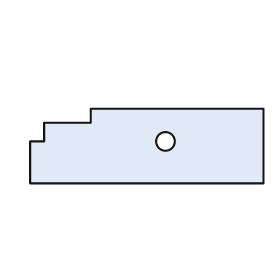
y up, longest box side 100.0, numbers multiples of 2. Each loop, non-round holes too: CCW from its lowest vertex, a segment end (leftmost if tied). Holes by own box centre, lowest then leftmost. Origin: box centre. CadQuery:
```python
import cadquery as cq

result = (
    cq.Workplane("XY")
    .moveTo(-50.0, -16.0)
    .lineTo(50.0, -16.0)
    .lineTo(50.0, 16.0)
    .lineTo(-24.0, 16.0)
    .lineTo(-24.0, 10.0)
    .lineTo(-44.0, 10.0)
    .lineTo(-44.0, 2.0)
    .lineTo(-50.0, 2.0)
    .close()
    .moveTo(8.0, 2.0)
    .circle(4.0)
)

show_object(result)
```